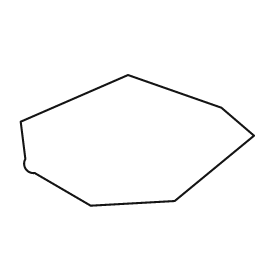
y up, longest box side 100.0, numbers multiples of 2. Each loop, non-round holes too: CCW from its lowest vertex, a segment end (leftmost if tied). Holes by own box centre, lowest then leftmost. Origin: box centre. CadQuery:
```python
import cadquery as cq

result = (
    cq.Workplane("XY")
    .moveTo(-20.0, -28.0)
    .lineTo(16.0, -26.0)
    .lineTo(50.0, 2.0)
    .lineTo(36.0, 14.0)
    .lineTo(-4.0, 28.0)
    .lineTo(-50.0, 8.0)
    .lineTo(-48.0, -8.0)
    .threePointArc((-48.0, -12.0), (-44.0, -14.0))
    .close()
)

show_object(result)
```